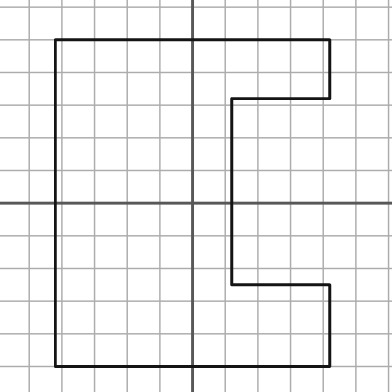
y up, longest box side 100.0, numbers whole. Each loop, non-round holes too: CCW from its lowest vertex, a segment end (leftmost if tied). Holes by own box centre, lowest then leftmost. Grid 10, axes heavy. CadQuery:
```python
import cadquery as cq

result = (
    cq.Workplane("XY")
    .moveTo(-42.0, -50.0)
    .lineTo(42.0, -50.0)
    .lineTo(42.0, -25.0)
    .lineTo(12.0, -25.0)
    .lineTo(12.0, 32.0)
    .lineTo(42.0, 32.0)
    .lineTo(42.0, 50.0)
    .lineTo(-42.0, 50.0)
    .close()
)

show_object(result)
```